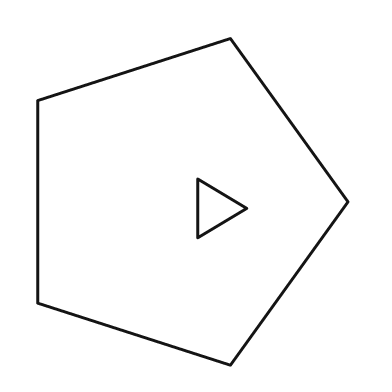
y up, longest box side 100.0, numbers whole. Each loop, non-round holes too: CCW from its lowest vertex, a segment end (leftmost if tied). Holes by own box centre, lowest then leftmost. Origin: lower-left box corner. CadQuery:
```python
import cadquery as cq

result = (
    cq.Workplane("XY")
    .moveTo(59.0, 0.0)
    .lineTo(95.0, 50.0)
    .lineTo(59.0, 100.0)
    .lineTo(0.0, 81.0)
    .lineTo(0.0, 19.0)
    .close()
    .moveTo(49.0, 39.0)
    .lineTo(64.0, 48.0)
    .lineTo(49.0, 57.0)
    .close()
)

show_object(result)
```